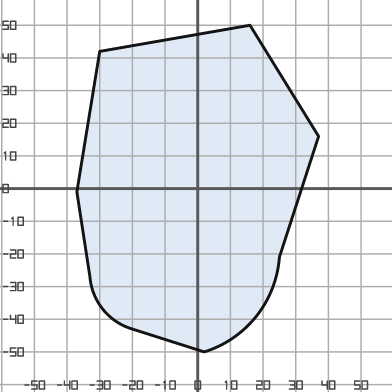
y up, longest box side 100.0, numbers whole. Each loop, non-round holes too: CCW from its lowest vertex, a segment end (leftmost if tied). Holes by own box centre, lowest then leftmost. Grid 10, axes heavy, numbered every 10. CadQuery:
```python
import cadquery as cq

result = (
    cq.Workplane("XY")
    .moveTo(2.0, -50.0)
    .threePointArc((18.0, -39.0), (25.0, -21.0))
    .lineTo(37.0, 16.0)
    .lineTo(16.0, 50.0)
    .lineTo(-30.0, 42.0)
    .lineTo(-37.0, -1.0)
    .lineTo(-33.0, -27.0)
    .threePointArc((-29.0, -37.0), (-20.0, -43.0))
    .close()
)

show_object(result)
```